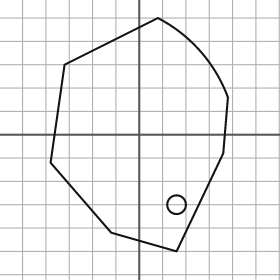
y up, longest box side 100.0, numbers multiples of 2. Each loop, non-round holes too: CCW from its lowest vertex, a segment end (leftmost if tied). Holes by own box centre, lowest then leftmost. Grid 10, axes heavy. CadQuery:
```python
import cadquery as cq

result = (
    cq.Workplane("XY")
    .moveTo(16.0, -50.0)
    .lineTo(36.0, -8.0)
    .lineTo(38.0, 16.0)
    .threePointArc((26.0, 36.0), (8.0, 50.0))
    .lineTo(-32.0, 30.0)
    .lineTo(-38.0, -12.0)
    .lineTo(-12.0, -42.0)
    .close()
    .moveTo(16.0, -30.0)
    .circle(4.0)
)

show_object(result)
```